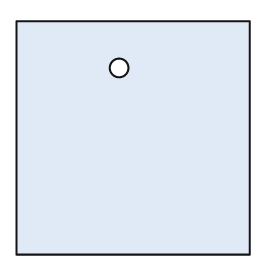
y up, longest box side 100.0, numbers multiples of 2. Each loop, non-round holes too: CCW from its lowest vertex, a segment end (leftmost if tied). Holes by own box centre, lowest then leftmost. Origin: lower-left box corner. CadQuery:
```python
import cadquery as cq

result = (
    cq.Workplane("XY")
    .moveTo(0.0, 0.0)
    .lineTo(100.0, 0.0)
    .lineTo(100.0, 100.0)
    .lineTo(0.0, 100.0)
    .close()
    .moveTo(44.0, 80.0)
    .circle(4.0)
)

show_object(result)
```